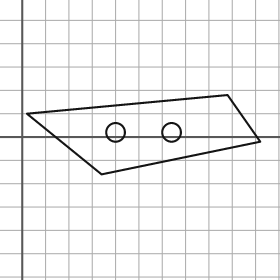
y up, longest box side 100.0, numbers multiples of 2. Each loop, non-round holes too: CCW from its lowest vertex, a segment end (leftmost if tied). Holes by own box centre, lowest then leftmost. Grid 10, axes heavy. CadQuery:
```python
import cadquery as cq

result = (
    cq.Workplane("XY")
    .moveTo(34.0, -16.0)
    .lineTo(102.0, -2.0)
    .lineTo(88.0, 18.0)
    .lineTo(2.0, 10.0)
    .close()
    .moveTo(40.0, 2.0)
    .circle(4.0)
    .moveTo(64.0, 2.0)
    .circle(4.0)
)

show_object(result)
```